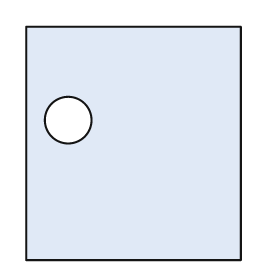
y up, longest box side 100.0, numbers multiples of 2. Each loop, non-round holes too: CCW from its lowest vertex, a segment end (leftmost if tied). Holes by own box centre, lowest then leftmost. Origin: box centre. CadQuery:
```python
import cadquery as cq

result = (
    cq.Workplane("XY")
    .moveTo(-46.0, -50.0)
    .lineTo(46.0, -50.0)
    .lineTo(46.0, 50.0)
    .lineTo(-46.0, 50.0)
    .close()
    .moveTo(-28.0, 10.0)
    .circle(10.0)
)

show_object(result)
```